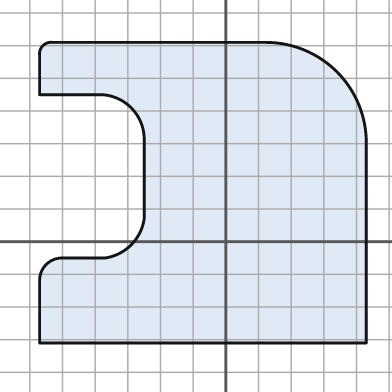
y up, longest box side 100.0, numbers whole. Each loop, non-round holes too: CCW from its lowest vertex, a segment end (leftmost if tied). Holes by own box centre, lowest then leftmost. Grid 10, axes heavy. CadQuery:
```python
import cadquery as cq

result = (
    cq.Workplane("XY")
    .moveTo(-57.0, -31.0)
    .lineTo(43.0, -31.0)
    .lineTo(43.0, 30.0)
    .threePointArc((34.0, 52.0), (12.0, 61.0))
    .lineTo(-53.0, 61.0)
    .threePointArc((-56.0, 60.0), (-57.0, 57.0))
    .lineTo(-57.0, 45.0)
    .lineTo(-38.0, 45.0)
    .threePointArc((-29.0, 41.0), (-25.0, 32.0))
    .lineTo(-25.0, 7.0)
    .threePointArc((-29.0, -1.0), (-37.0, -5.0))
    .lineTo(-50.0, -5.0)
    .threePointArc((-55.0, -7.0), (-57.0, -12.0))
    .close()
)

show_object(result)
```